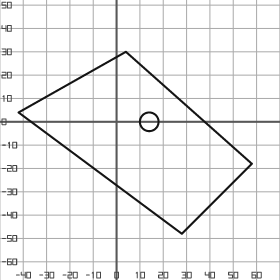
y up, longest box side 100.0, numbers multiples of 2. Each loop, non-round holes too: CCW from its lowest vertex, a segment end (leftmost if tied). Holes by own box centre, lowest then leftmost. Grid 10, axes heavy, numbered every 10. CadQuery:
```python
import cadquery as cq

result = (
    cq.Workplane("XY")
    .moveTo(28.0, -48.0)
    .lineTo(58.0, -18.0)
    .lineTo(4.0, 30.0)
    .lineTo(-42.0, 4.0)
    .close()
    .moveTo(14.0, 0.0)
    .circle(4.0)
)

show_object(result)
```